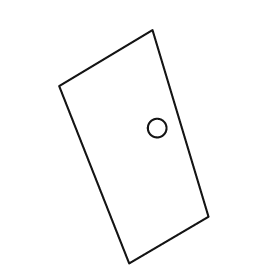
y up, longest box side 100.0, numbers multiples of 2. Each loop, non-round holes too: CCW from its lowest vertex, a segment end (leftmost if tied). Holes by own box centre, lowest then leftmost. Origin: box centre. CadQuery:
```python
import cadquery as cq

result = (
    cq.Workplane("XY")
    .moveTo(-2.0, -50.0)
    .lineTo(32.0, -30.0)
    .lineTo(8.0, 50.0)
    .lineTo(-32.0, 26.0)
    .close()
    .moveTo(10.0, 8.0)
    .circle(4.0)
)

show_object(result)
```